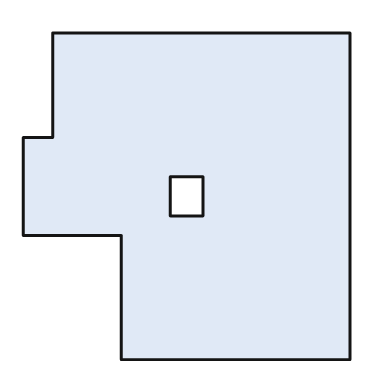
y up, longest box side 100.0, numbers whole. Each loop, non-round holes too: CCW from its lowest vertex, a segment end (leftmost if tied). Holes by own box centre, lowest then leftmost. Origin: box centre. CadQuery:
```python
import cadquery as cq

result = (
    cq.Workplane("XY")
    .moveTo(-20.0, -50.0)
    .lineTo(50.0, -50.0)
    .lineTo(50.0, 50.0)
    .lineTo(-41.0, 50.0)
    .lineTo(-41.0, 18.0)
    .lineTo(-50.0, 18.0)
    .lineTo(-50.0, -12.0)
    .lineTo(-20.0, -12.0)
    .close()
    .moveTo(-5.0, -6.0)
    .lineTo(5.0, -6.0)
    .lineTo(5.0, 6.0)
    .lineTo(-5.0, 6.0)
    .close()
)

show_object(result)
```